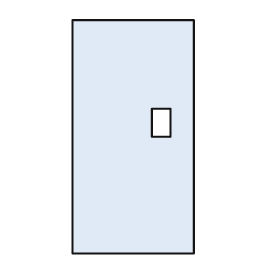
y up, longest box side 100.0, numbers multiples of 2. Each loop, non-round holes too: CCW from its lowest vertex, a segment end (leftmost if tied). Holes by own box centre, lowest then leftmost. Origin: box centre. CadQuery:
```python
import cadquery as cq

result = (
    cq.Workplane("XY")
    .moveTo(-26.0, -50.0)
    .lineTo(26.0, -50.0)
    .lineTo(26.0, 50.0)
    .lineTo(-26.0, 50.0)
    .close()
    .moveTo(8.0, 0.0)
    .lineTo(16.0, 0.0)
    .lineTo(16.0, 12.0)
    .lineTo(8.0, 12.0)
    .close()
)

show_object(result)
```